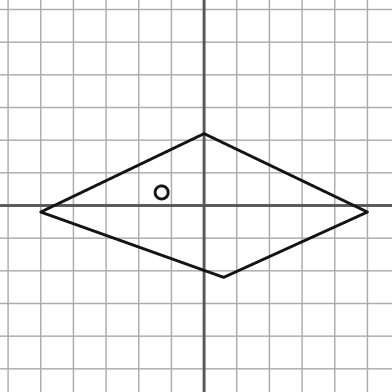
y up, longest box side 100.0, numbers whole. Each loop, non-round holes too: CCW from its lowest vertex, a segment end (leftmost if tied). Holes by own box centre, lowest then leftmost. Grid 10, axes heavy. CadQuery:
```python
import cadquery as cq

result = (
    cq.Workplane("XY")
    .moveTo(6.0, -22.0)
    .lineTo(50.0, -2.0)
    .lineTo(0.0, 22.0)
    .lineTo(-50.0, -2.0)
    .close()
    .moveTo(-13.0, 4.0)
    .circle(2.0)
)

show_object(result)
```